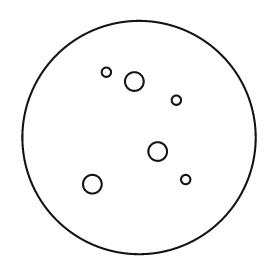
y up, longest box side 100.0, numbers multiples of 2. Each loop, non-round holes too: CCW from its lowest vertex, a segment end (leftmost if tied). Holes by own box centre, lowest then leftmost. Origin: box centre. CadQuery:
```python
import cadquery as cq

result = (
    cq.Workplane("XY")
    .moveTo(0.0, 0.0)
    .circle(50.0)
    .moveTo(-20.0, -20.0)
    .circle(4.0)
    .moveTo(20.0, -18.0)
    .circle(2.0)
    .moveTo(8.0, -6.0)
    .circle(4.0)
    .moveTo(16.0, 16.0)
    .circle(2.0)
    .moveTo(-2.0, 24.0)
    .circle(4.0)
    .moveTo(-14.0, 28.0)
    .circle(2.0)
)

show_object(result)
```